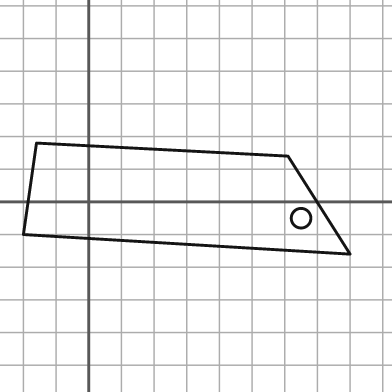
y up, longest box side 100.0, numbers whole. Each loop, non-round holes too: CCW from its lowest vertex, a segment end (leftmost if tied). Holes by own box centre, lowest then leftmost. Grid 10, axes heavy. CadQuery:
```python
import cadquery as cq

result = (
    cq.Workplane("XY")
    .moveTo(80.0, -16.0)
    .lineTo(61.0, 14.0)
    .lineTo(-16.0, 18.0)
    .lineTo(-20.0, -10.0)
    .close()
    .moveTo(65.0, -5.0)
    .circle(3.0)
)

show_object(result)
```